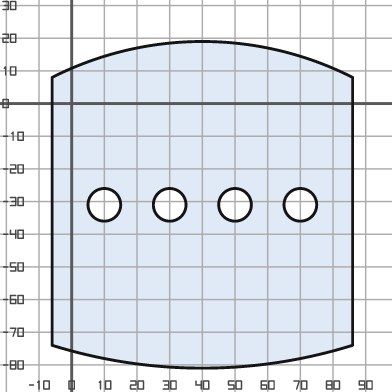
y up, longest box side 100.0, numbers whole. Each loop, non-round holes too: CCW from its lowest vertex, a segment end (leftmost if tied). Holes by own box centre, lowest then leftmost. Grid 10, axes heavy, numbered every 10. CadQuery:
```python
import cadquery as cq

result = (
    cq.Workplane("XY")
    .moveTo(-6.0, -74.0)
    .threePointArc((40.0, -81.0), (86.0, -74.0))
    .lineTo(86.0, 8.0)
    .threePointArc((40.0, 19.0), (-6.0, 8.0))
    .close()
    .moveTo(10.0, -31.0)
    .circle(5.0)
    .moveTo(30.0, -31.0)
    .circle(5.0)
    .moveTo(50.0, -31.0)
    .circle(5.0)
    .moveTo(70.0, -31.0)
    .circle(5.0)
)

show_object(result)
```